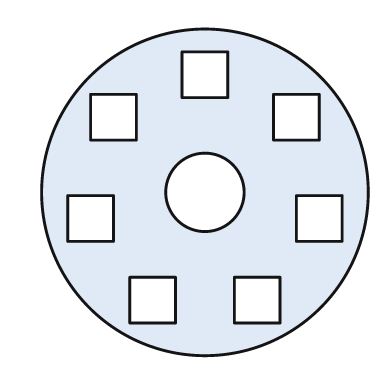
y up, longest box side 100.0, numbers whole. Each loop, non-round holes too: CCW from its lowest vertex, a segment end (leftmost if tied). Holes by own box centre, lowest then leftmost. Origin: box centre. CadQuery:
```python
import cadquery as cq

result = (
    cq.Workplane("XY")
    .moveTo(0.0, 0.0)
    .circle(50.0)
    .moveTo(-23.0, -40.0)
    .lineTo(-9.0, -40.0)
    .lineTo(-9.0, -26.0)
    .lineTo(-23.0, -26.0)
    .close()
    .moveTo(9.0, -40.0)
    .lineTo(23.0, -40.0)
    .lineTo(23.0, -26.0)
    .lineTo(9.0, -26.0)
    .close()
    .moveTo(-42.0, -15.0)
    .lineTo(-28.0, -15.0)
    .lineTo(-28.0, -1.0)
    .lineTo(-42.0, -1.0)
    .close()
    .moveTo(28.0, -15.0)
    .lineTo(42.0, -15.0)
    .lineTo(42.0, -1.0)
    .lineTo(28.0, -1.0)
    .close()
    .moveTo(0.0, 0.0)
    .circle(12.0)
    .moveTo(-35.0, 16.0)
    .lineTo(-21.0, 16.0)
    .lineTo(-21.0, 30.0)
    .lineTo(-35.0, 30.0)
    .close()
    .moveTo(21.0, 16.0)
    .lineTo(35.0, 16.0)
    .lineTo(35.0, 30.0)
    .lineTo(21.0, 30.0)
    .close()
    .moveTo(-7.0, 29.0)
    .lineTo(7.0, 29.0)
    .lineTo(7.0, 43.0)
    .lineTo(-7.0, 43.0)
    .close()
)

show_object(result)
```